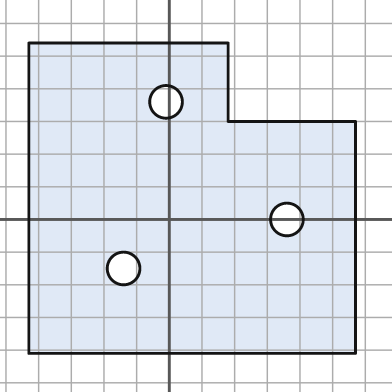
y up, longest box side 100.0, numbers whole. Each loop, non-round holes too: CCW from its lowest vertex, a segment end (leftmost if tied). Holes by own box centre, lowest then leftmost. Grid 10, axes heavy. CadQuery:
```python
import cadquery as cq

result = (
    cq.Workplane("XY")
    .moveTo(-43.0, -41.0)
    .lineTo(57.0, -41.0)
    .lineTo(57.0, 30.0)
    .lineTo(18.0, 30.0)
    .lineTo(18.0, 54.0)
    .lineTo(-43.0, 54.0)
    .close()
    .moveTo(-14.0, -15.0)
    .circle(5.0)
    .moveTo(36.0, 0.0)
    .circle(5.0)
    .moveTo(-1.0, 36.0)
    .circle(5.0)
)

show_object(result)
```